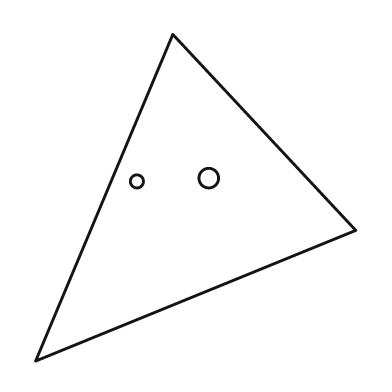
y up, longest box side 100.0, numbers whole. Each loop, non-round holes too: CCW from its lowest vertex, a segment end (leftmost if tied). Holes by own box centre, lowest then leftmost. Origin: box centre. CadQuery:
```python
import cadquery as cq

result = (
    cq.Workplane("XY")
    .moveTo(-49.0, -50.0)
    .lineTo(49.0, -10.0)
    .lineTo(-7.0, 50.0)
    .close()
    .moveTo(-18.0, 5.0)
    .circle(2.0)
    .moveTo(4.0, 6.0)
    .circle(3.0)
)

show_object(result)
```